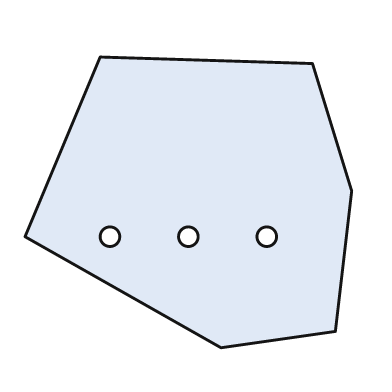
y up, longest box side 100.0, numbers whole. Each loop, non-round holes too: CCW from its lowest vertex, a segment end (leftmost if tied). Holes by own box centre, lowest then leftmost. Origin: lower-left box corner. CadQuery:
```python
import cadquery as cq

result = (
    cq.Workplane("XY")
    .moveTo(60.0, 0.0)
    .lineTo(95.0, 5.0)
    .lineTo(100.0, 48.0)
    .lineTo(88.0, 87.0)
    .lineTo(23.0, 89.0)
    .lineTo(0.0, 34.0)
    .close()
    .moveTo(26.0, 34.0)
    .circle(3.0)
    .moveTo(50.0, 34.0)
    .circle(3.0)
    .moveTo(74.0, 34.0)
    .circle(3.0)
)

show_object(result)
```